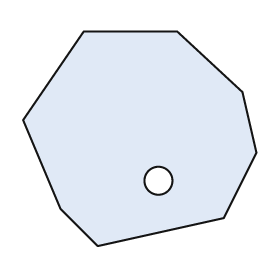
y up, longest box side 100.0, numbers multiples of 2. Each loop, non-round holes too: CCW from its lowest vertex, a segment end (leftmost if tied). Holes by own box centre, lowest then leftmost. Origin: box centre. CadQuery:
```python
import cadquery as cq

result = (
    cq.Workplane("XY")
    .moveTo(-18.0, -46.0)
    .lineTo(36.0, -34.0)
    .lineTo(50.0, -6.0)
    .lineTo(44.0, 20.0)
    .lineTo(16.0, 46.0)
    .lineTo(-24.0, 46.0)
    .lineTo(-50.0, 8.0)
    .lineTo(-34.0, -30.0)
    .close()
    .moveTo(8.0, -18.0)
    .circle(6.0)
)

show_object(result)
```